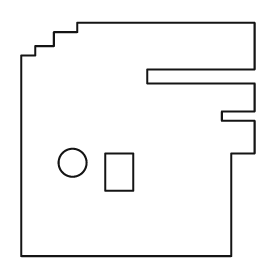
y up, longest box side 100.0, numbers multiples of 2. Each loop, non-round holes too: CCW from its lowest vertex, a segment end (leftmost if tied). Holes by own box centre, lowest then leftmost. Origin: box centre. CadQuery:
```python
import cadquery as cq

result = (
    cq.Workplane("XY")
    .moveTo(-50.0, -50.0)
    .lineTo(40.0, -50.0)
    .lineTo(40.0, -6.0)
    .lineTo(50.0, -6.0)
    .lineTo(50.0, 8.0)
    .lineTo(36.0, 8.0)
    .lineTo(36.0, 12.0)
    .lineTo(50.0, 12.0)
    .lineTo(50.0, 24.0)
    .lineTo(4.0, 24.0)
    .lineTo(4.0, 30.0)
    .lineTo(50.0, 30.0)
    .lineTo(50.0, 50.0)
    .lineTo(-26.0, 50.0)
    .lineTo(-26.0, 46.0)
    .lineTo(-36.0, 46.0)
    .lineTo(-36.0, 40.0)
    .lineTo(-44.0, 40.0)
    .lineTo(-44.0, 36.0)
    .lineTo(-50.0, 36.0)
    .close()
    .moveTo(-14.0, -22.0)
    .lineTo(-2.0, -22.0)
    .lineTo(-2.0, -6.0)
    .lineTo(-14.0, -6.0)
    .close()
    .moveTo(-28.0, -10.0)
    .circle(6.0)
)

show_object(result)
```